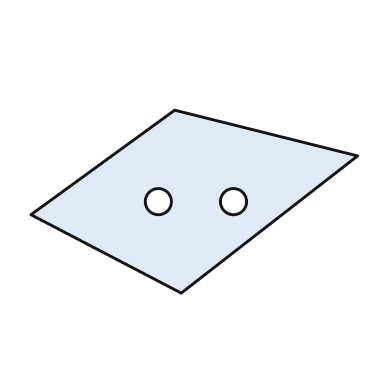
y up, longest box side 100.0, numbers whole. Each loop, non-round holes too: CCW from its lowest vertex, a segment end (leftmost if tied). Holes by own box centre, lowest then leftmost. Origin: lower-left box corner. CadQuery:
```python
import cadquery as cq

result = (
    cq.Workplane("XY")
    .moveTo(46.0, 0.0)
    .lineTo(100.0, 42.0)
    .lineTo(44.0, 56.0)
    .lineTo(0.0, 24.0)
    .close()
    .moveTo(39.0, 28.0)
    .circle(4.0)
    .moveTo(62.0, 28.0)
    .circle(4.0)
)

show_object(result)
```